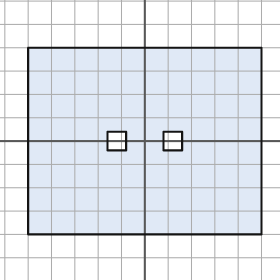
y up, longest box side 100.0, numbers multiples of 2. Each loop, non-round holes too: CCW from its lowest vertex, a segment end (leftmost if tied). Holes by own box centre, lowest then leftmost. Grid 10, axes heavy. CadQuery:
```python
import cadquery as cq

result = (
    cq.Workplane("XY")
    .moveTo(-50.0, -40.0)
    .lineTo(50.0, -40.0)
    .lineTo(50.0, 40.0)
    .lineTo(-50.0, 40.0)
    .close()
    .moveTo(-16.0, -4.0)
    .lineTo(-8.0, -4.0)
    .lineTo(-8.0, 4.0)
    .lineTo(-16.0, 4.0)
    .close()
    .moveTo(8.0, -4.0)
    .lineTo(16.0, -4.0)
    .lineTo(16.0, 4.0)
    .lineTo(8.0, 4.0)
    .close()
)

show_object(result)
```